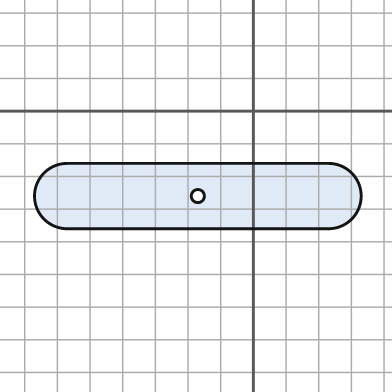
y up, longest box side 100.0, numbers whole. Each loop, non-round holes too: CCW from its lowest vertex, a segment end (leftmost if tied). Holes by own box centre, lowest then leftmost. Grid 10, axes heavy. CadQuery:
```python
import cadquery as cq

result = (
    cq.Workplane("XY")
    .moveTo(-57.0, -36.0)
    .lineTo(23.0, -36.0)
    .threePointArc((33.0, -26.0), (23.0, -16.0))
    .lineTo(-57.0, -16.0)
    .threePointArc((-67.0, -26.0), (-57.0, -36.0))
    .close()
    .moveTo(-17.0, -26.0)
    .circle(2.0)
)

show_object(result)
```